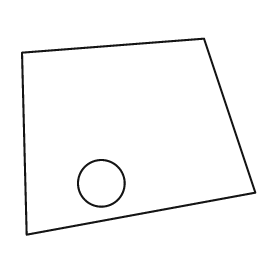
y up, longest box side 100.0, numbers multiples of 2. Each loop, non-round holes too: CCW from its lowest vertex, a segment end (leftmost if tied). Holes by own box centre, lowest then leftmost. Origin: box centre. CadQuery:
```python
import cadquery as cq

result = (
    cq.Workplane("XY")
    .moveTo(-48.0, -42.0)
    .lineTo(50.0, -24.0)
    .lineTo(28.0, 42.0)
    .lineTo(-50.0, 36.0)
    .close()
    .moveTo(-16.0, -20.0)
    .circle(10.0)
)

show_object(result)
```